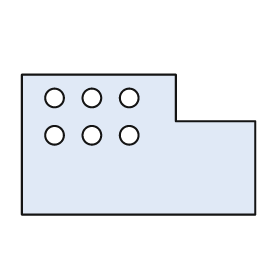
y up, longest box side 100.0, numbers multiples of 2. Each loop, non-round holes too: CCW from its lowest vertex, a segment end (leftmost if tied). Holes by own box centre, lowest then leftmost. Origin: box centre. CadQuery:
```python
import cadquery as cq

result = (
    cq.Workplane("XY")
    .moveTo(-50.0, -30.0)
    .lineTo(50.0, -30.0)
    .lineTo(50.0, 10.0)
    .lineTo(16.0, 10.0)
    .lineTo(16.0, 30.0)
    .lineTo(-50.0, 30.0)
    .close()
    .moveTo(-36.0, 4.0)
    .circle(4.0)
    .moveTo(-20.0, 4.0)
    .circle(4.0)
    .moveTo(-4.0, 4.0)
    .circle(4.0)
    .moveTo(-36.0, 20.0)
    .circle(4.0)
    .moveTo(-20.0, 20.0)
    .circle(4.0)
    .moveTo(-4.0, 20.0)
    .circle(4.0)
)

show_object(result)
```